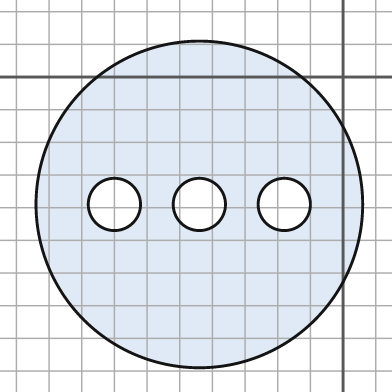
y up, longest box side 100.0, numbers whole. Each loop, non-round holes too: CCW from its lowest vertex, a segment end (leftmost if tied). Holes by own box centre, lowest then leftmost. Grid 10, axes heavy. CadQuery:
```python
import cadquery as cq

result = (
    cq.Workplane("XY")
    .moveTo(-44.0, -39.0)
    .circle(50.0)
    .moveTo(-70.0, -39.0)
    .circle(8.0)
    .moveTo(-44.0, -39.0)
    .circle(8.0)
    .moveTo(-18.0, -39.0)
    .circle(8.0)
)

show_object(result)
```